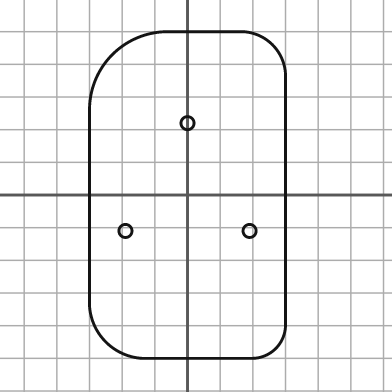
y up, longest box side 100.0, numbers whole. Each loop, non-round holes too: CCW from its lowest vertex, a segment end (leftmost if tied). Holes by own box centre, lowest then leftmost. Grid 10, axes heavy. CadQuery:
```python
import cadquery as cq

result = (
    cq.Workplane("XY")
    .moveTo(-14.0, -50.0)
    .lineTo(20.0, -50.0)
    .threePointArc((27.0, -47.0), (30.0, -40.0))
    .lineTo(30.0, 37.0)
    .threePointArc((26.0, 46.0), (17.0, 50.0))
    .lineTo(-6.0, 50.0)
    .threePointArc((-23.0, 43.0), (-30.0, 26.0))
    .lineTo(-30.0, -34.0)
    .threePointArc((-25.0, -45.0), (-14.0, -50.0))
    .close()
    .moveTo(-19.0, -11.0)
    .circle(2.0)
    .moveTo(19.0, -11.0)
    .circle(2.0)
    .moveTo(0.0, 22.0)
    .circle(2.0)
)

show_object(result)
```